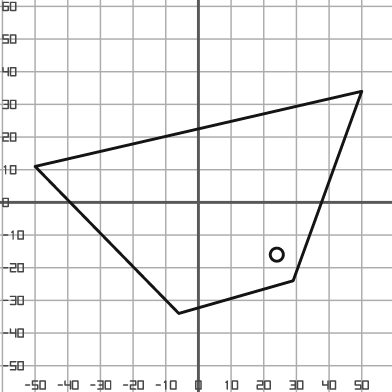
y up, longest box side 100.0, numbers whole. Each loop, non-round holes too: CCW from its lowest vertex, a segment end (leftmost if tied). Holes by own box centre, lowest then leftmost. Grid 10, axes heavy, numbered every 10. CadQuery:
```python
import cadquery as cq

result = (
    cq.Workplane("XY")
    .moveTo(-6.0, -34.0)
    .lineTo(29.0, -24.0)
    .lineTo(50.0, 34.0)
    .lineTo(-50.0, 11.0)
    .close()
    .moveTo(24.0, -16.0)
    .circle(2.0)
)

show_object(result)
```